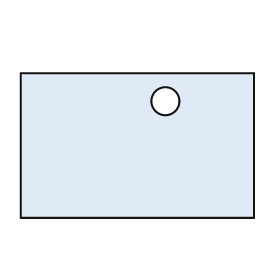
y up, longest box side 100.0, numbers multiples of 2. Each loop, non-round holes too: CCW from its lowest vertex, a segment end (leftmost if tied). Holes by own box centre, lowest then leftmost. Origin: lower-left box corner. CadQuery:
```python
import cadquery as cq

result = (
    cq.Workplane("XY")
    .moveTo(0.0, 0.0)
    .lineTo(100.0, 0.0)
    .lineTo(100.0, 62.0)
    .lineTo(0.0, 62.0)
    .close()
    .moveTo(62.0, 50.0)
    .circle(6.0)
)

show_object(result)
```